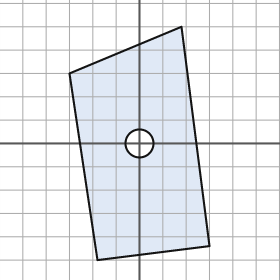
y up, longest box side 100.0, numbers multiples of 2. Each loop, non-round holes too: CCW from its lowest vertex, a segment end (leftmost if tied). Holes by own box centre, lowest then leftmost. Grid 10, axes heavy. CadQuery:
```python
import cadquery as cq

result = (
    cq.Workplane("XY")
    .moveTo(-18.0, -50.0)
    .lineTo(30.0, -44.0)
    .lineTo(18.0, 50.0)
    .lineTo(-30.0, 30.0)
    .close()
    .moveTo(0.0, 0.0)
    .circle(6.0)
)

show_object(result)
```